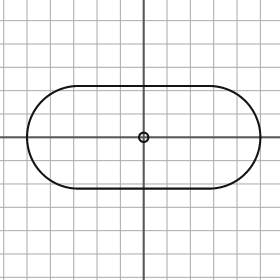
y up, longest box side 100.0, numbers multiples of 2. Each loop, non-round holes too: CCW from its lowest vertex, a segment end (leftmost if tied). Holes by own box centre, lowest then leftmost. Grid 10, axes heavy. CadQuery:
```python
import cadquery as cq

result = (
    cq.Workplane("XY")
    .moveTo(-28.0, -22.0)
    .lineTo(28.0, -22.0)
    .threePointArc((50.0, 0.0), (28.0, 22.0))
    .lineTo(-28.0, 22.0)
    .threePointArc((-50.0, 0.0), (-28.0, -22.0))
    .close()
    .moveTo(0.0, 0.0)
    .circle(2.0)
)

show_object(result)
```